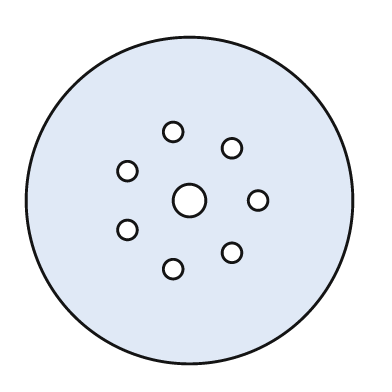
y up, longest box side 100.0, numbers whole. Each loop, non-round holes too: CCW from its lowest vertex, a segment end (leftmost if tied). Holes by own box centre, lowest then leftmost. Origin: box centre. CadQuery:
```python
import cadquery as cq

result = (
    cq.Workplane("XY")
    .moveTo(0.0, 0.0)
    .circle(50.0)
    .moveTo(-5.0, -21.0)
    .circle(3.0)
    .moveTo(13.0, -16.0)
    .circle(3.0)
    .moveTo(-19.0, -9.0)
    .circle(3.0)
    .moveTo(0.0, 0.0)
    .circle(5.0)
    .moveTo(21.0, 0.0)
    .circle(3.0)
    .moveTo(-19.0, 9.0)
    .circle(3.0)
    .moveTo(13.0, 16.0)
    .circle(3.0)
    .moveTo(-5.0, 21.0)
    .circle(3.0)
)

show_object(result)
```